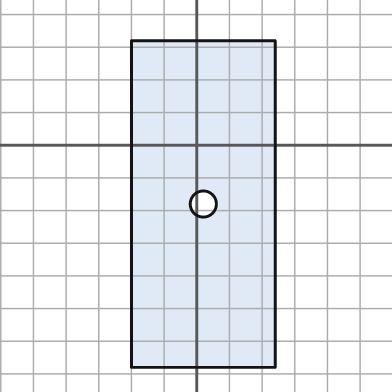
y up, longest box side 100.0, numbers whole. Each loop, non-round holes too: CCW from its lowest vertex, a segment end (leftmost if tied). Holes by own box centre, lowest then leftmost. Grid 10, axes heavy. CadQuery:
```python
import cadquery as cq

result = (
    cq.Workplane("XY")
    .moveTo(-20.0, -68.0)
    .lineTo(24.0, -68.0)
    .lineTo(24.0, 32.0)
    .lineTo(-20.0, 32.0)
    .close()
    .moveTo(2.0, -18.0)
    .circle(4.0)
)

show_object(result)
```